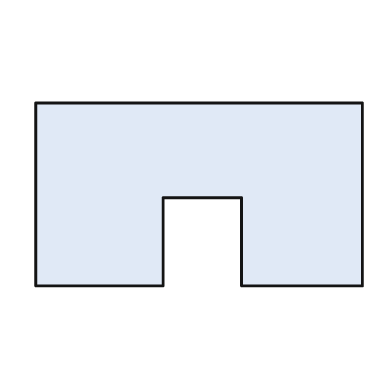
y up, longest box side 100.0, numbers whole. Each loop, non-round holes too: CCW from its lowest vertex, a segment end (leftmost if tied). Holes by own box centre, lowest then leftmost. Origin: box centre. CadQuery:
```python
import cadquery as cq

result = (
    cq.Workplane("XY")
    .moveTo(-50.0, -28.0)
    .lineTo(-11.0, -28.0)
    .lineTo(-11.0, -1.0)
    .lineTo(13.0, -1.0)
    .lineTo(13.0, -28.0)
    .lineTo(50.0, -28.0)
    .lineTo(50.0, 28.0)
    .lineTo(-50.0, 28.0)
    .close()
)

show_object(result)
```